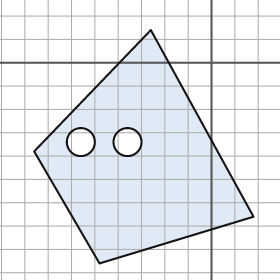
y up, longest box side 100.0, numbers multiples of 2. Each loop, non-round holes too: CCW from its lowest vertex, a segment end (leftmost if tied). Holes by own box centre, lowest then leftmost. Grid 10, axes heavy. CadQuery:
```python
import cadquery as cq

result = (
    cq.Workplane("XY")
    .moveTo(-48.0, -86.0)
    .lineTo(18.0, -66.0)
    .lineTo(-26.0, 14.0)
    .lineTo(-76.0, -38.0)
    .close()
    .moveTo(-56.0, -34.0)
    .circle(6.0)
    .moveTo(-36.0, -34.0)
    .circle(6.0)
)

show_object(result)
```